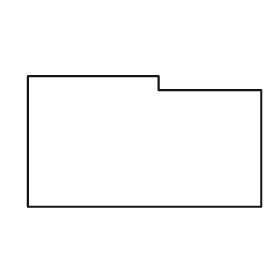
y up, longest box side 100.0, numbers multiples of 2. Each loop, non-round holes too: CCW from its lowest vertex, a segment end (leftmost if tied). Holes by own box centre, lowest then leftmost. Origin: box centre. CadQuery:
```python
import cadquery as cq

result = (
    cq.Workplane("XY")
    .moveTo(-50.0, -28.0)
    .lineTo(50.0, -28.0)
    .lineTo(50.0, 22.0)
    .lineTo(6.0, 22.0)
    .lineTo(6.0, 28.0)
    .lineTo(-50.0, 28.0)
    .close()
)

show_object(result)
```